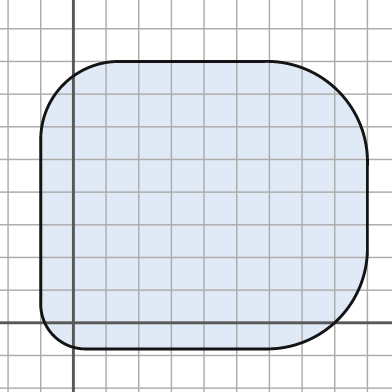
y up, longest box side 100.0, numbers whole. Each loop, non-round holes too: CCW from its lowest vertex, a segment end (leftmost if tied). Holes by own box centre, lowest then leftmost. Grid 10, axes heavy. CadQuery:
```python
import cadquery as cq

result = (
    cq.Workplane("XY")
    .moveTo(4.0, -8.0)
    .lineTo(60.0, -8.0)
    .threePointArc((81.0, 1.0), (90.0, 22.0))
    .lineTo(90.0, 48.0)
    .threePointArc((81.0, 71.0), (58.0, 80.0))
    .lineTo(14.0, 80.0)
    .threePointArc((-3.0, 73.0), (-10.0, 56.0))
    .lineTo(-10.0, 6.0)
    .threePointArc((-6.0, -4.0), (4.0, -8.0))
    .close()
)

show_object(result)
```